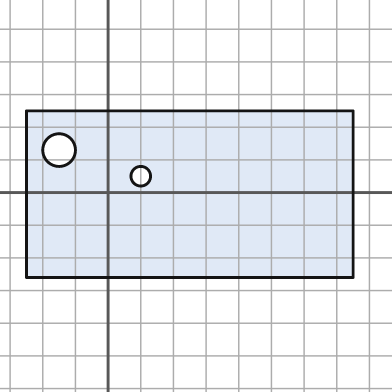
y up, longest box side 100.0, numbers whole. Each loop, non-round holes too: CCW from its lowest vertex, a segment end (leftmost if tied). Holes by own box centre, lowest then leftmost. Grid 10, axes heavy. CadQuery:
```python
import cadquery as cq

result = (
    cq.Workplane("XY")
    .moveTo(-25.0, -26.0)
    .lineTo(75.0, -26.0)
    .lineTo(75.0, 25.0)
    .lineTo(-25.0, 25.0)
    .close()
    .moveTo(10.0, 5.0)
    .circle(3.0)
    .moveTo(-15.0, 13.0)
    .circle(5.0)
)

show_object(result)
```